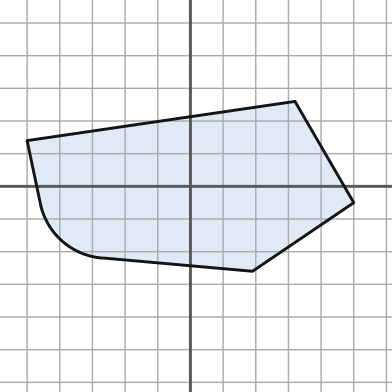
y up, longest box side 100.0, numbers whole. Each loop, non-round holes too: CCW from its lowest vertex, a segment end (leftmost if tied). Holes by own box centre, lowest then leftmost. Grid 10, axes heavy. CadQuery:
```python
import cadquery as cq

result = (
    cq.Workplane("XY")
    .moveTo(19.0, -26.0)
    .lineTo(50.0, -5.0)
    .lineTo(32.0, 26.0)
    .lineTo(-50.0, 14.0)
    .lineTo(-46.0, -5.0)
    .threePointArc((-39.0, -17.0), (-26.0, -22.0))
    .close()
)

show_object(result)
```